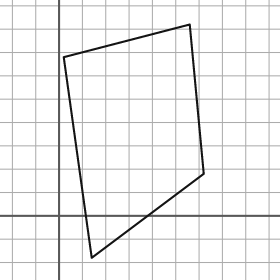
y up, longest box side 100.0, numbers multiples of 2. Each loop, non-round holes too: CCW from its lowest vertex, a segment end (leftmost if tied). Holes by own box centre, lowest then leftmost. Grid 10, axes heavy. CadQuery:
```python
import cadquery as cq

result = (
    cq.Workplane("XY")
    .moveTo(14.0, -18.0)
    .lineTo(62.0, 18.0)
    .lineTo(56.0, 82.0)
    .lineTo(2.0, 68.0)
    .close()
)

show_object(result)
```